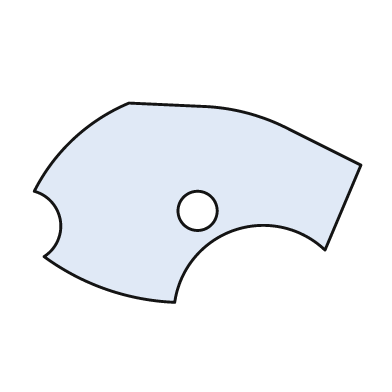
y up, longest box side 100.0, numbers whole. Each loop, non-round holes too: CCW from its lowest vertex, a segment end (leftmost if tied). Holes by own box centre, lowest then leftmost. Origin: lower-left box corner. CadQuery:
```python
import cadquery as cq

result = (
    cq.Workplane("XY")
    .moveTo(43.0, 0.0)
    .threePointArc((61.0, 22.0), (89.0, 16.0))
    .lineTo(100.0, 42.0)
    .lineTo(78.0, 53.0)
    .threePointArc((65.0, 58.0), (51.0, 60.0))
    .lineTo(29.0, 61.0)
    .threePointArc((12.0, 50.0), (0.0, 34.0))
    .threePointArc((8.0, 25.0), (3.0, 14.0))
    .threePointArc((22.0, 4.0), (43.0, 0.0))
    .close()
    .moveTo(50.0, 28.0)
    .circle(6.0)
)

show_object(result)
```